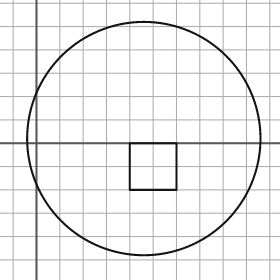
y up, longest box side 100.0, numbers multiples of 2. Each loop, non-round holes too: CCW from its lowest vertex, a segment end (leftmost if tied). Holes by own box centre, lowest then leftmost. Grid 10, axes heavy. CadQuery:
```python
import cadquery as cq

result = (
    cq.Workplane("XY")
    .moveTo(46.0, 2.0)
    .circle(50.0)
    .moveTo(40.0, -20.0)
    .lineTo(60.0, -20.0)
    .lineTo(60.0, 0.0)
    .lineTo(40.0, 0.0)
    .close()
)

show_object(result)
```